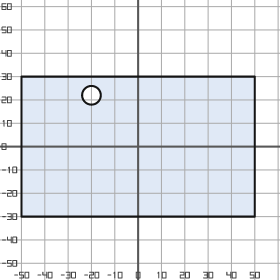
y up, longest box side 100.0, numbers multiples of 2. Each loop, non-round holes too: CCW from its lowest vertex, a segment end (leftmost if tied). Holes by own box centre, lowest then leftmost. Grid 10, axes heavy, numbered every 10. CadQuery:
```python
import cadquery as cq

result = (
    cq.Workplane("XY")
    .moveTo(-50.0, -30.0)
    .lineTo(50.0, -30.0)
    .lineTo(50.0, 30.0)
    .lineTo(-50.0, 30.0)
    .close()
    .moveTo(-20.0, 22.0)
    .circle(4.0)
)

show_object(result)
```